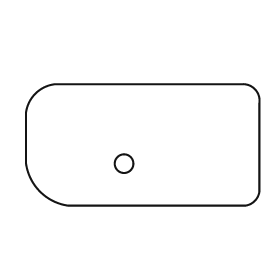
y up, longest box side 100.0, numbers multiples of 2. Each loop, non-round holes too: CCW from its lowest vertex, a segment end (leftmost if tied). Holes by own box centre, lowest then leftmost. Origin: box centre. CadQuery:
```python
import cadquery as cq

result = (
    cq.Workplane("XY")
    .moveTo(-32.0, -26.0)
    .lineTo(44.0, -26.0)
    .threePointArc((48.0, -24.0), (50.0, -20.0))
    .lineTo(50.0, 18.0)
    .threePointArc((48.0, 24.0), (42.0, 26.0))
    .lineTo(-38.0, 26.0)
    .threePointArc((-46.0, 22.0), (-50.0, 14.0))
    .lineTo(-50.0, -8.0)
    .threePointArc((-44.0, -20.0), (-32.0, -26.0))
    .close()
    .moveTo(-8.0, -8.0)
    .circle(4.0)
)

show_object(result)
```